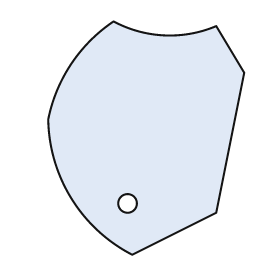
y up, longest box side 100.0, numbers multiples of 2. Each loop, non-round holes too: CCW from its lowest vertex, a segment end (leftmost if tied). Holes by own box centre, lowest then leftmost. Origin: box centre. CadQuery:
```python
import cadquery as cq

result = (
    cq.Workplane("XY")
    .moveTo(-6.0, -50.0)
    .lineTo(30.0, -32.0)
    .lineTo(42.0, 28.0)
    .lineTo(30.0, 48.0)
    .threePointArc((8.0, 44.0), (-14.0, 50.0))
    .threePointArc((-32.0, 32.0), (-42.0, 8.0))
    .threePointArc((-32.0, -26.0), (-6.0, -50.0))
    .close()
    .moveTo(-8.0, -28.0)
    .circle(4.0)
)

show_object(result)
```